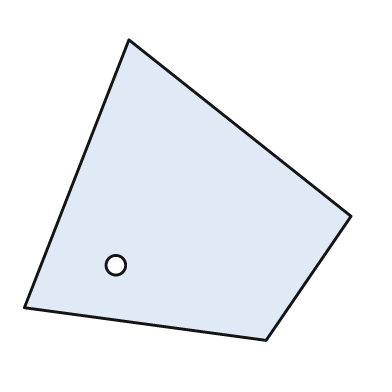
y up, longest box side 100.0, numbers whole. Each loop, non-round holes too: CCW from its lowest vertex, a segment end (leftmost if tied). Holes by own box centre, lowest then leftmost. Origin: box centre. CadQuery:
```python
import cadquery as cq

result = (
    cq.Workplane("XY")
    .moveTo(24.0, -46.0)
    .lineTo(50.0, -8.0)
    .lineTo(-18.0, 46.0)
    .lineTo(-50.0, -36.0)
    .close()
    .moveTo(-22.0, -23.0)
    .circle(3.0)
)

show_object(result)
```